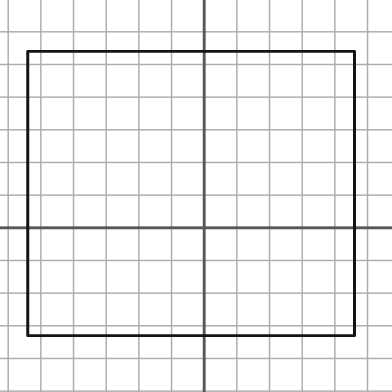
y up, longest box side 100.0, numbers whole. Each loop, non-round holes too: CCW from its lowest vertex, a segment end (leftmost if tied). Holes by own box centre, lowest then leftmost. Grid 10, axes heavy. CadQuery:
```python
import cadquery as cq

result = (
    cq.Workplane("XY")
    .moveTo(-54.0, -33.0)
    .lineTo(46.0, -33.0)
    .lineTo(46.0, 54.0)
    .lineTo(-54.0, 54.0)
    .close()
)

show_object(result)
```